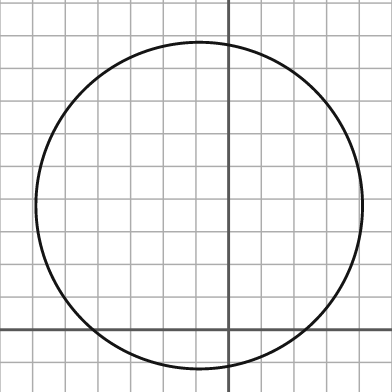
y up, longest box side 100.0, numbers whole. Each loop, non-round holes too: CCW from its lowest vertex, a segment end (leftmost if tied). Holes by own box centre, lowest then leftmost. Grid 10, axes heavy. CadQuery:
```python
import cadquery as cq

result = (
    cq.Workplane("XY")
    .moveTo(-9.0, 38.0)
    .circle(50.0)
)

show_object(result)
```